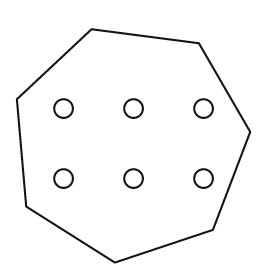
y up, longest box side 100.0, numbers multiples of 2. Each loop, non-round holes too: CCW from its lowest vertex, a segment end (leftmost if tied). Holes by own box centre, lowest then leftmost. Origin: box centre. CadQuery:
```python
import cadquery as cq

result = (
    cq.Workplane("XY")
    .moveTo(-8.0, -50.0)
    .lineTo(34.0, -36.0)
    .lineTo(50.0, 6.0)
    .lineTo(28.0, 44.0)
    .lineTo(-18.0, 50.0)
    .lineTo(-50.0, 20.0)
    .lineTo(-46.0, -26.0)
    .close()
    .moveTo(-30.0, -14.0)
    .circle(4.0)
    .moveTo(0.0, -14.0)
    .circle(4.0)
    .moveTo(30.0, -14.0)
    .circle(4.0)
    .moveTo(-30.0, 16.0)
    .circle(4.0)
    .moveTo(0.0, 16.0)
    .circle(4.0)
    .moveTo(30.0, 16.0)
    .circle(4.0)
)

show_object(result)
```